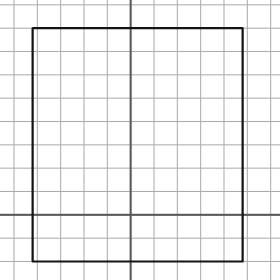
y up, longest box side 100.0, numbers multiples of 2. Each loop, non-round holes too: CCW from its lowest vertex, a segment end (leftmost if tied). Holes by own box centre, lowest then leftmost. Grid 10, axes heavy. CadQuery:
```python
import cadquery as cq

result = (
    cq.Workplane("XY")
    .moveTo(-42.0, -20.0)
    .lineTo(48.0, -20.0)
    .lineTo(48.0, 80.0)
    .lineTo(-42.0, 80.0)
    .close()
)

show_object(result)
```